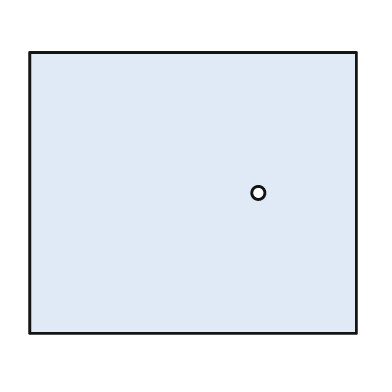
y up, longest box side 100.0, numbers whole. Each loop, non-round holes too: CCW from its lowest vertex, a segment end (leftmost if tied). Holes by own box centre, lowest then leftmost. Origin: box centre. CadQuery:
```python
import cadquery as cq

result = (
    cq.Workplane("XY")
    .moveTo(-50.0, -43.0)
    .lineTo(50.0, -43.0)
    .lineTo(50.0, 43.0)
    .lineTo(-50.0, 43.0)
    .close()
    .moveTo(20.0, 0.0)
    .circle(2.0)
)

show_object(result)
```